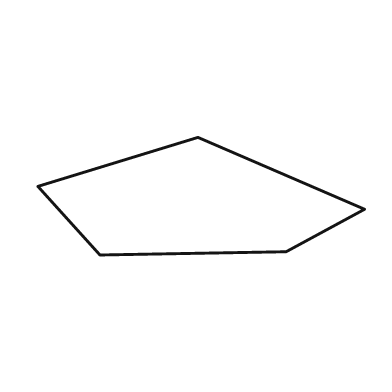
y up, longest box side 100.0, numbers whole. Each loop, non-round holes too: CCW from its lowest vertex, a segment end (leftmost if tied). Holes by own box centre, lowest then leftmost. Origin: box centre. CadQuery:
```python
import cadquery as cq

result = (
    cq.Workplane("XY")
    .moveTo(-31.0, -18.0)
    .lineTo(26.0, -17.0)
    .lineTo(50.0, -4.0)
    .lineTo(-1.0, 18.0)
    .lineTo(-50.0, 3.0)
    .close()
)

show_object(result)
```